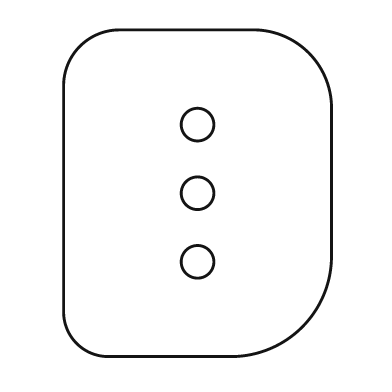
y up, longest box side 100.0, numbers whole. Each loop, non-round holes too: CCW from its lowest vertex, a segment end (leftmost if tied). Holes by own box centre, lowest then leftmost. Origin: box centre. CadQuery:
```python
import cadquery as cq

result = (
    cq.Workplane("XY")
    .moveTo(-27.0, -50.0)
    .lineTo(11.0, -50.0)
    .threePointArc((32.0, -41.0), (41.0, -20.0))
    .lineTo(41.0, 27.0)
    .threePointArc((34.0, 43.0), (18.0, 50.0))
    .lineTo(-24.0, 50.0)
    .threePointArc((-36.0, 45.0), (-41.0, 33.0))
    .lineTo(-41.0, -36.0)
    .threePointArc((-37.0, -46.0), (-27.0, -50.0))
    .close()
    .moveTo(0.0, -21.0)
    .circle(5.0)
    .moveTo(0.0, 0.0)
    .circle(5.0)
    .moveTo(0.0, 21.0)
    .circle(5.0)
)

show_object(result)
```